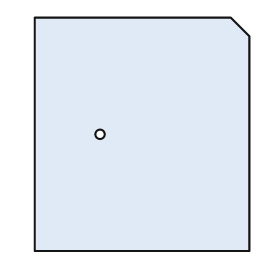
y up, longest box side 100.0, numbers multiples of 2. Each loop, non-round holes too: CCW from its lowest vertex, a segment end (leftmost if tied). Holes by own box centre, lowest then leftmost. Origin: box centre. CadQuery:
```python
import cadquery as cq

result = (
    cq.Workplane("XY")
    .moveTo(-46.0, -50.0)
    .lineTo(46.0, -50.0)
    .lineTo(46.0, 42.0)
    .lineTo(38.0, 50.0)
    .lineTo(-46.0, 50.0)
    .close()
    .moveTo(-18.0, 0.0)
    .circle(2.0)
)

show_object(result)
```